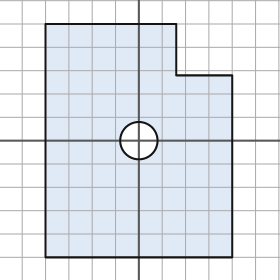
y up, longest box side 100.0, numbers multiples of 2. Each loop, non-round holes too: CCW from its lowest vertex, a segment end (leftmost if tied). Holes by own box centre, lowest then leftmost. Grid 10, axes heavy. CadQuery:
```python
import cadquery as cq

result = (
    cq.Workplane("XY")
    .moveTo(-40.0, -50.0)
    .lineTo(40.0, -50.0)
    .lineTo(40.0, 28.0)
    .lineTo(16.0, 28.0)
    .lineTo(16.0, 50.0)
    .lineTo(-40.0, 50.0)
    .close()
    .moveTo(0.0, 0.0)
    .circle(8.0)
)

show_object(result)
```